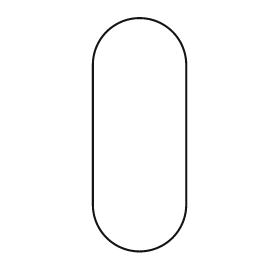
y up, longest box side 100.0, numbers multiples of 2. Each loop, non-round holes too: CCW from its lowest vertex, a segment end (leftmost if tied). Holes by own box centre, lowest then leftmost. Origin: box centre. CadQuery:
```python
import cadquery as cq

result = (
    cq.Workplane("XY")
    .moveTo(-20.0, -30.0)
    .threePointArc((0.0, -50.0), (20.0, -30.0))
    .lineTo(20.0, 30.0)
    .threePointArc((0.0, 50.0), (-20.0, 30.0))
    .close()
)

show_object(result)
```